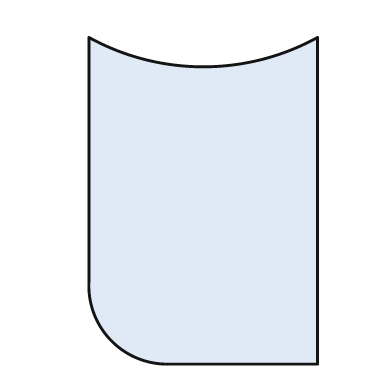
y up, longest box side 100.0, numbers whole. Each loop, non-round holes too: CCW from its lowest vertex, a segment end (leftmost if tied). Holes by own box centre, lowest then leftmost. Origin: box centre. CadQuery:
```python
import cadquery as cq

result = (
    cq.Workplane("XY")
    .moveTo(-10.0, -50.0)
    .lineTo(35.0, -50.0)
    .lineTo(35.0, 50.0)
    .threePointArc((0.0, 41.0), (-35.0, 50.0))
    .lineTo(-35.0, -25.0)
    .threePointArc((-28.0, -43.0), (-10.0, -50.0))
    .close()
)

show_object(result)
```